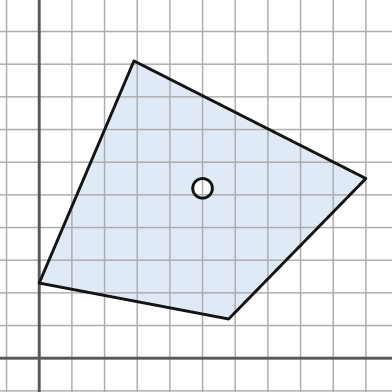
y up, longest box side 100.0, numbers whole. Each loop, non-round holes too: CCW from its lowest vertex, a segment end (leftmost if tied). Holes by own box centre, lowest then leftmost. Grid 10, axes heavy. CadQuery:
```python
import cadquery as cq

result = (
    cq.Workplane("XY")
    .moveTo(58.0, 12.0)
    .lineTo(100.0, 55.0)
    .lineTo(29.0, 91.0)
    .lineTo(0.0, 23.0)
    .close()
    .moveTo(50.0, 52.0)
    .circle(3.0)
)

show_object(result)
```